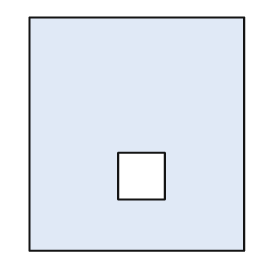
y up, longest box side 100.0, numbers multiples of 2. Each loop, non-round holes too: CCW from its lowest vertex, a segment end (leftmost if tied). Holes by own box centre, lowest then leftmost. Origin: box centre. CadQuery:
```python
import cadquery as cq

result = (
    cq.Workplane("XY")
    .moveTo(-46.0, -50.0)
    .lineTo(46.0, -50.0)
    .lineTo(46.0, 50.0)
    .lineTo(-46.0, 50.0)
    .close()
    .moveTo(-8.0, -28.0)
    .lineTo(12.0, -28.0)
    .lineTo(12.0, -8.0)
    .lineTo(-8.0, -8.0)
    .close()
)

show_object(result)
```